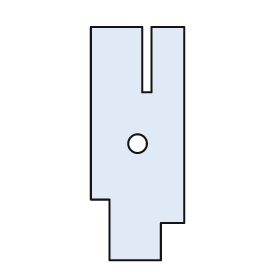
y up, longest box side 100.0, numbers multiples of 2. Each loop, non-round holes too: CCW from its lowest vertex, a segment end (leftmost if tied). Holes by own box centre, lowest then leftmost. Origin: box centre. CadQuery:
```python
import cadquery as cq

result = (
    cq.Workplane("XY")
    .moveTo(-12.0, -50.0)
    .lineTo(10.0, -50.0)
    .lineTo(10.0, -34.0)
    .lineTo(20.0, -34.0)
    .lineTo(20.0, 50.0)
    .lineTo(6.0, 50.0)
    .lineTo(6.0, 22.0)
    .lineTo(2.0, 22.0)
    .lineTo(2.0, 50.0)
    .lineTo(-20.0, 50.0)
    .lineTo(-20.0, -24.0)
    .lineTo(-12.0, -24.0)
    .close()
    .moveTo(0.0, 0.0)
    .circle(4.0)
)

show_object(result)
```